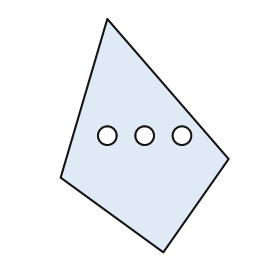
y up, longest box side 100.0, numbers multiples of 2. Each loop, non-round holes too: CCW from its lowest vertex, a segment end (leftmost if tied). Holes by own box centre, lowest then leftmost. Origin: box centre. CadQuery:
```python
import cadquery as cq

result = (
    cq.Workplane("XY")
    .moveTo(8.0, -50.0)
    .lineTo(36.0, -10.0)
    .lineTo(-16.0, 50.0)
    .lineTo(-36.0, -18.0)
    .close()
    .moveTo(-16.0, 0.0)
    .circle(4.0)
    .moveTo(0.0, 0.0)
    .circle(4.0)
    .moveTo(16.0, 0.0)
    .circle(4.0)
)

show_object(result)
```